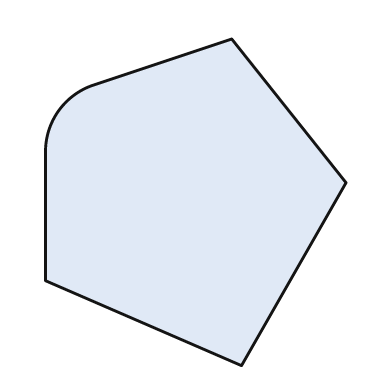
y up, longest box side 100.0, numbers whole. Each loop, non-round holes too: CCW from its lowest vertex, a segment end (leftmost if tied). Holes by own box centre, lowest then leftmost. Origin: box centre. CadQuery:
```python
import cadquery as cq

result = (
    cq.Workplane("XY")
    .moveTo(14.0, -50.0)
    .lineTo(46.0, 6.0)
    .lineTo(11.0, 50.0)
    .lineTo(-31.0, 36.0)
    .threePointArc((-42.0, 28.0), (-46.0, 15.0))
    .lineTo(-46.0, -24.0)
    .close()
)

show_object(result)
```